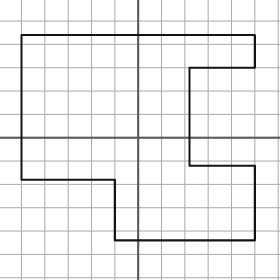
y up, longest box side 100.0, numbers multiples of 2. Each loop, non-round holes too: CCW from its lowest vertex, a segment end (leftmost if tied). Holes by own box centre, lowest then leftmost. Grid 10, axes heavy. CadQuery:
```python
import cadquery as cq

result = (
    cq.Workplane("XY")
    .moveTo(-10.0, -44.0)
    .lineTo(50.0, -44.0)
    .lineTo(50.0, -12.0)
    .lineTo(22.0, -12.0)
    .lineTo(22.0, 30.0)
    .lineTo(50.0, 30.0)
    .lineTo(50.0, 44.0)
    .lineTo(-50.0, 44.0)
    .lineTo(-50.0, -18.0)
    .lineTo(-10.0, -18.0)
    .close()
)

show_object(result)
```